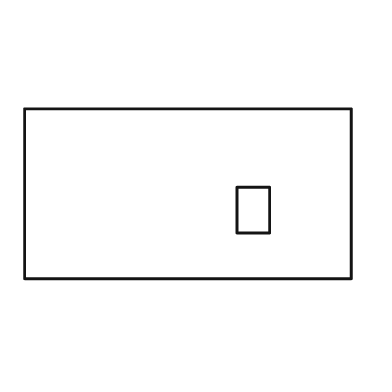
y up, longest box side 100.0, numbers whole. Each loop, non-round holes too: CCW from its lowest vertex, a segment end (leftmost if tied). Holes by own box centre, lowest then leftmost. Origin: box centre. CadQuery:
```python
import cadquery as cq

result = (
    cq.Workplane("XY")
    .moveTo(-50.0, -26.0)
    .lineTo(50.0, -26.0)
    .lineTo(50.0, 26.0)
    .lineTo(-50.0, 26.0)
    .close()
    .moveTo(15.0, -12.0)
    .lineTo(25.0, -12.0)
    .lineTo(25.0, 2.0)
    .lineTo(15.0, 2.0)
    .close()
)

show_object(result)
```